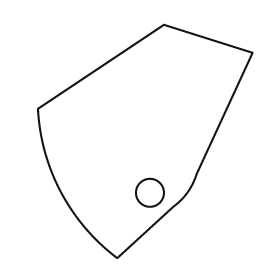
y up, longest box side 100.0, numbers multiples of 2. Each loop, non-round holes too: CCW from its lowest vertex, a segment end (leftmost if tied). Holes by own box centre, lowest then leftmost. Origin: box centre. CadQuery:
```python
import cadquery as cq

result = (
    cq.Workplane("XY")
    .moveTo(-12.0, -50.0)
    .lineTo(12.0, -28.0)
    .threePointArc((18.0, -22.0), (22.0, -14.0))
    .lineTo(46.0, 38.0)
    .lineTo(8.0, 50.0)
    .lineTo(-46.0, 14.0)
    .threePointArc((-36.0, -22.0), (-12.0, -50.0))
    .close()
    .moveTo(2.0, -22.0)
    .circle(6.0)
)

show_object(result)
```